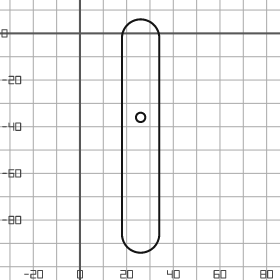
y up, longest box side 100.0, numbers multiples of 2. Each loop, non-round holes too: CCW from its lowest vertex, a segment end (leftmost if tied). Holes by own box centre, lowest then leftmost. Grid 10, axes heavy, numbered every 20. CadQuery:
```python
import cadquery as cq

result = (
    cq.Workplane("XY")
    .moveTo(18.0, -86.0)
    .threePointArc((26.0, -94.0), (34.0, -86.0))
    .lineTo(34.0, -2.0)
    .threePointArc((26.0, 6.0), (18.0, -2.0))
    .close()
    .moveTo(26.0, -36.0)
    .circle(2.0)
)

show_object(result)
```